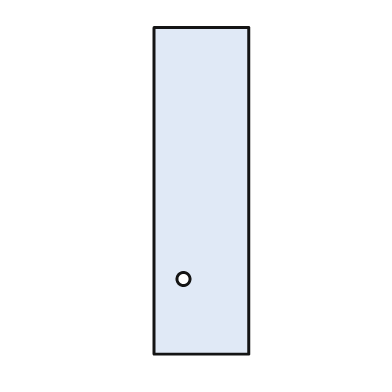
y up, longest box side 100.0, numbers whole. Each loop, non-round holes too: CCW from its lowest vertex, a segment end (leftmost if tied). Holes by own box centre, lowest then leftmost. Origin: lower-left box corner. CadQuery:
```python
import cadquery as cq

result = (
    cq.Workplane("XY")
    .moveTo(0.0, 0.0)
    .lineTo(29.0, 0.0)
    .lineTo(29.0, 100.0)
    .lineTo(0.0, 100.0)
    .close()
    .moveTo(9.0, 23.0)
    .circle(2.0)
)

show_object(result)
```